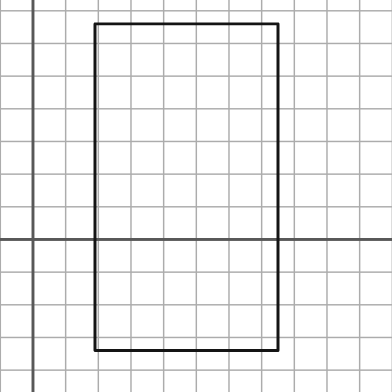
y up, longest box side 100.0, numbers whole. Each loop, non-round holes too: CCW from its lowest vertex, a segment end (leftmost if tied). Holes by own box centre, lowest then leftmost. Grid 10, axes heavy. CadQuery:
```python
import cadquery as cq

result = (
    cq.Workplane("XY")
    .moveTo(19.0, -34.0)
    .lineTo(75.0, -34.0)
    .lineTo(75.0, 66.0)
    .lineTo(19.0, 66.0)
    .close()
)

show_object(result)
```